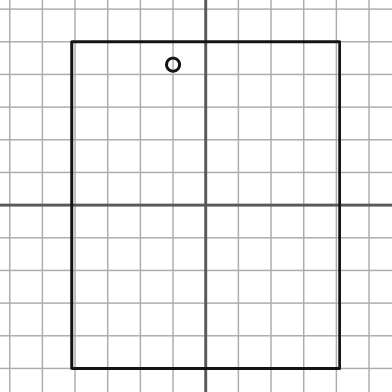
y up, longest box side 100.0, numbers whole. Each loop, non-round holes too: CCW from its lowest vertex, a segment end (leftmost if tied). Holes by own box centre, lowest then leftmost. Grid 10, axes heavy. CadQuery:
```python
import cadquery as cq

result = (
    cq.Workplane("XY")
    .moveTo(-41.0, -50.0)
    .lineTo(41.0, -50.0)
    .lineTo(41.0, 50.0)
    .lineTo(-41.0, 50.0)
    .close()
    .moveTo(-10.0, 43.0)
    .circle(2.0)
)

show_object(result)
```